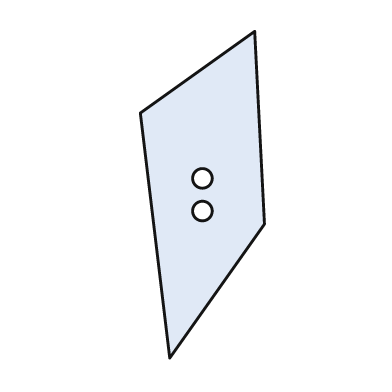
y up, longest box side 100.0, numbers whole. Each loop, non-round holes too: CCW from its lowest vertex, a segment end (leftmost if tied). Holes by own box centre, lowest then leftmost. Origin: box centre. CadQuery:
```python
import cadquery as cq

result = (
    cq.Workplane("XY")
    .moveTo(-10.0, -50.0)
    .lineTo(19.0, -9.0)
    .lineTo(16.0, 50.0)
    .lineTo(-19.0, 25.0)
    .close()
    .moveTo(0.0, -5.0)
    .circle(3.0)
    .moveTo(0.0, 5.0)
    .circle(3.0)
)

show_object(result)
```